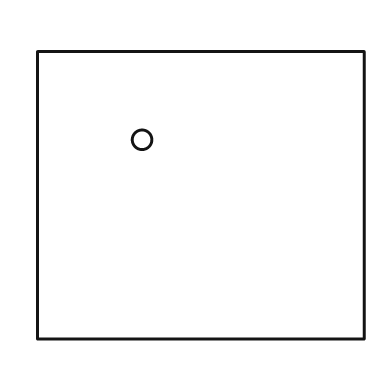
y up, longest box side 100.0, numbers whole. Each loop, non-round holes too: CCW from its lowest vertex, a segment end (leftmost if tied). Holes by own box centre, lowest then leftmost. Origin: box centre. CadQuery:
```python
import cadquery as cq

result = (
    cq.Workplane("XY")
    .moveTo(-50.0, -44.0)
    .lineTo(50.0, -44.0)
    .lineTo(50.0, 44.0)
    .lineTo(-50.0, 44.0)
    .close()
    .moveTo(-18.0, 17.0)
    .circle(3.0)
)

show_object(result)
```